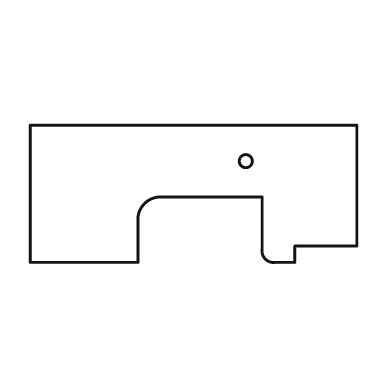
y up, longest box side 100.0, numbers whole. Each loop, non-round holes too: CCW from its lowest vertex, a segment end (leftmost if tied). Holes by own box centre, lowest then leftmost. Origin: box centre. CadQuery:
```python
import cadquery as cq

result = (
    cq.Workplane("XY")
    .moveTo(-50.0, -21.0)
    .lineTo(-17.0, -21.0)
    .lineTo(-17.0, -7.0)
    .threePointArc((-15.0, -3.0), (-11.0, -1.0))
    .lineTo(21.0, -1.0)
    .lineTo(21.0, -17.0)
    .threePointArc((22.0, -20.0), (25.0, -21.0))
    .lineTo(31.0, -21.0)
    .lineTo(31.0, -16.0)
    .lineTo(50.0, -16.0)
    .lineTo(50.0, 21.0)
    .lineTo(-50.0, 21.0)
    .close()
    .moveTo(16.0, 10.0)
    .circle(2.0)
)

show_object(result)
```